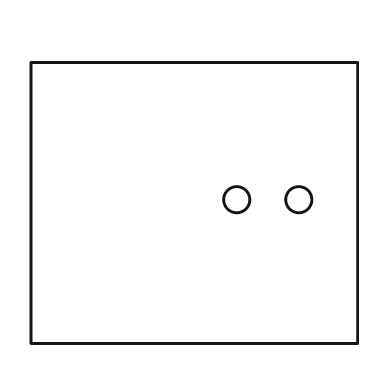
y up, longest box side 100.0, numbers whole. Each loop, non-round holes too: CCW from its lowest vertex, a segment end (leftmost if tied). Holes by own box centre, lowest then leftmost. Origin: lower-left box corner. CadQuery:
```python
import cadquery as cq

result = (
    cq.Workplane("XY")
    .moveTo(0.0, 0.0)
    .lineTo(100.0, 0.0)
    .lineTo(100.0, 86.0)
    .lineTo(0.0, 86.0)
    .close()
    .moveTo(63.0, 44.0)
    .circle(4.0)
    .moveTo(82.0, 44.0)
    .circle(4.0)
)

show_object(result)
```